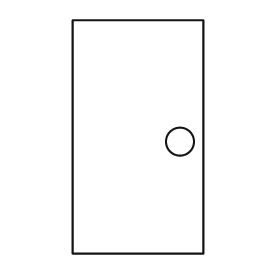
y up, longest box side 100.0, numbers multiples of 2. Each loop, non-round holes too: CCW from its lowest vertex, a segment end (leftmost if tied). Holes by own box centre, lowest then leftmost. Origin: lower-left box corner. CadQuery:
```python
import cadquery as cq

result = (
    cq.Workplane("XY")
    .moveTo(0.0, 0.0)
    .lineTo(56.0, 0.0)
    .lineTo(56.0, 100.0)
    .lineTo(0.0, 100.0)
    .close()
    .moveTo(46.0, 48.0)
    .circle(6.0)
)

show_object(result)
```